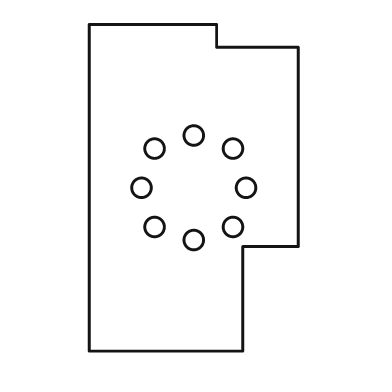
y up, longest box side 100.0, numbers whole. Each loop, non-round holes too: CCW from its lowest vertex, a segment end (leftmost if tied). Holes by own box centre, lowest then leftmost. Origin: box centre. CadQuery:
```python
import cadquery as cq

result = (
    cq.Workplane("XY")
    .moveTo(-32.0, -50.0)
    .lineTo(15.0, -50.0)
    .lineTo(15.0, -18.0)
    .lineTo(32.0, -18.0)
    .lineTo(32.0, 43.0)
    .lineTo(7.0, 43.0)
    .lineTo(7.0, 50.0)
    .lineTo(-32.0, 50.0)
    .close()
    .moveTo(0.0, -16.0)
    .circle(3.0)
    .moveTo(-12.0, -12.0)
    .circle(3.0)
    .moveTo(12.0, -12.0)
    .circle(3.0)
    .moveTo(-16.0, 0.0)
    .circle(3.0)
    .moveTo(16.0, 0.0)
    .circle(3.0)
    .moveTo(-12.0, 12.0)
    .circle(3.0)
    .moveTo(12.0, 12.0)
    .circle(3.0)
    .moveTo(0.0, 16.0)
    .circle(3.0)
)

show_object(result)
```